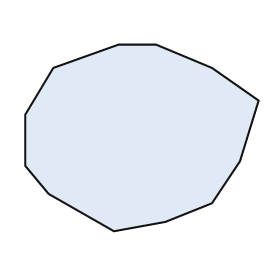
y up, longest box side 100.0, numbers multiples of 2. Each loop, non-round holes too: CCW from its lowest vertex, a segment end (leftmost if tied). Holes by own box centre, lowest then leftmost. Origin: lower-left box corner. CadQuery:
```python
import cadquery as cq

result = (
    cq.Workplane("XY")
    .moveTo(38.0, 0.0)
    .lineTo(60.0, 4.0)
    .lineTo(80.0, 12.0)
    .lineTo(92.0, 30.0)
    .lineTo(100.0, 56.0)
    .lineTo(80.0, 70.0)
    .lineTo(56.0, 80.0)
    .lineTo(40.0, 80.0)
    .lineTo(12.0, 70.0)
    .lineTo(0.0, 50.0)
    .lineTo(0.0, 28.0)
    .lineTo(10.0, 16.0)
    .close()
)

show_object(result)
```